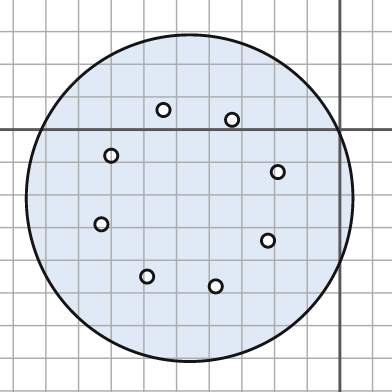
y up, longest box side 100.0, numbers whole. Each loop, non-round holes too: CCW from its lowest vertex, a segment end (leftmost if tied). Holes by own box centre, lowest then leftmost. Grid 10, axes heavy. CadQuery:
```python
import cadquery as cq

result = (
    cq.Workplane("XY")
    .moveTo(-46.0, -21.0)
    .circle(50.0)
    .moveTo(-38.0, -48.0)
    .circle(2.0)
    .moveTo(-59.0, -45.0)
    .circle(2.0)
    .moveTo(-22.0, -34.0)
    .circle(2.0)
    .moveTo(-73.0, -29.0)
    .circle(2.0)
    .moveTo(-19.0, -13.0)
    .circle(2.0)
    .moveTo(-70.0, -8.0)
    .circle(2.0)
    .moveTo(-33.0, 3.0)
    .circle(2.0)
    .moveTo(-54.0, 6.0)
    .circle(2.0)
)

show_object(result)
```